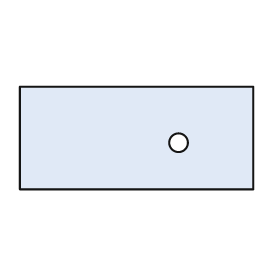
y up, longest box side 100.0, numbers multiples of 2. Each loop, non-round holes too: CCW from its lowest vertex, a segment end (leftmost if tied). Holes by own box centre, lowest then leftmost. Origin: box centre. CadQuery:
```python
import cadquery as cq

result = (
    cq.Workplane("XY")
    .moveTo(-50.0, -22.0)
    .lineTo(50.0, -22.0)
    .lineTo(50.0, 22.0)
    .lineTo(-50.0, 22.0)
    .close()
    .moveTo(18.0, -2.0)
    .circle(4.0)
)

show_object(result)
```